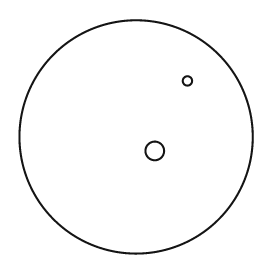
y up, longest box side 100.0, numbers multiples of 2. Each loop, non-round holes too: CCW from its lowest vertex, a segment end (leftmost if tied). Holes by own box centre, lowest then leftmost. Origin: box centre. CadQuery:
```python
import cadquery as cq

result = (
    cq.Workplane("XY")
    .moveTo(0.0, 0.0)
    .circle(50.0)
    .moveTo(8.0, -6.0)
    .circle(4.0)
    .moveTo(22.0, 24.0)
    .circle(2.0)
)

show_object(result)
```